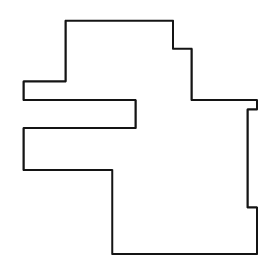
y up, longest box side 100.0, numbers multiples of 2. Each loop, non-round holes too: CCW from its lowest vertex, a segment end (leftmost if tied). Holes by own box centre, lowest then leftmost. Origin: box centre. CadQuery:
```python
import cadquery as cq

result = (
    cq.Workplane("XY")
    .moveTo(-12.0, -50.0)
    .lineTo(50.0, -50.0)
    .lineTo(50.0, -30.0)
    .lineTo(46.0, -30.0)
    .lineTo(46.0, 12.0)
    .lineTo(50.0, 12.0)
    .lineTo(50.0, 16.0)
    .lineTo(22.0, 16.0)
    .lineTo(22.0, 38.0)
    .lineTo(14.0, 38.0)
    .lineTo(14.0, 50.0)
    .lineTo(-32.0, 50.0)
    .lineTo(-32.0, 24.0)
    .lineTo(-50.0, 24.0)
    .lineTo(-50.0, 16.0)
    .lineTo(-2.0, 16.0)
    .lineTo(-2.0, 4.0)
    .lineTo(-50.0, 4.0)
    .lineTo(-50.0, -14.0)
    .lineTo(-12.0, -14.0)
    .close()
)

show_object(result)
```